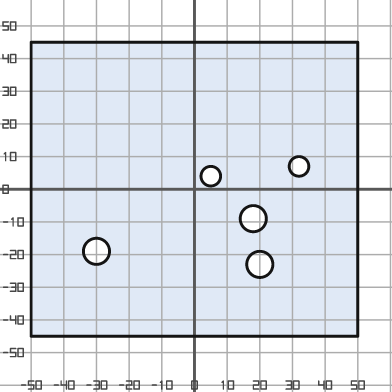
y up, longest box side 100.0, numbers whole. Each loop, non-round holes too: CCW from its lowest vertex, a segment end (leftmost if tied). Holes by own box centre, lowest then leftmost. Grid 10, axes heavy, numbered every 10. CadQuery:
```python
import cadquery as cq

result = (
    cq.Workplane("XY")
    .moveTo(-50.0, -45.0)
    .lineTo(50.0, -45.0)
    .lineTo(50.0, 45.0)
    .lineTo(-50.0, 45.0)
    .close()
    .moveTo(20.0, -23.0)
    .circle(4.0)
    .moveTo(-30.0, -19.0)
    .circle(4.0)
    .moveTo(18.0, -9.0)
    .circle(4.0)
    .moveTo(5.0, 4.0)
    .circle(3.0)
    .moveTo(32.0, 7.0)
    .circle(3.0)
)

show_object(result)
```